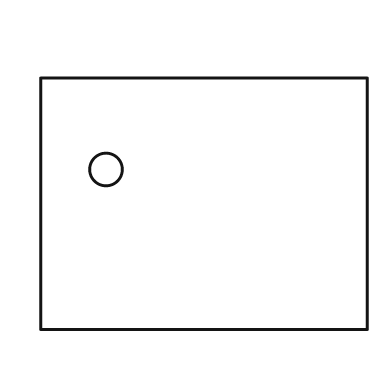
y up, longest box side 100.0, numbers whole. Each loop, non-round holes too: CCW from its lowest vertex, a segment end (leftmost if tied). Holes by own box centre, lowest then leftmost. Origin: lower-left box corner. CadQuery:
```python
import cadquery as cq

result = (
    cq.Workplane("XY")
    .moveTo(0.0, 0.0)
    .lineTo(100.0, 0.0)
    .lineTo(100.0, 77.0)
    .lineTo(0.0, 77.0)
    .close()
    .moveTo(20.0, 49.0)
    .circle(5.0)
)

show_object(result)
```